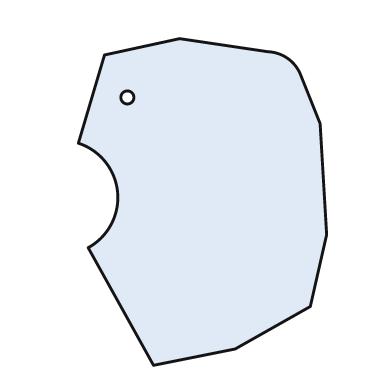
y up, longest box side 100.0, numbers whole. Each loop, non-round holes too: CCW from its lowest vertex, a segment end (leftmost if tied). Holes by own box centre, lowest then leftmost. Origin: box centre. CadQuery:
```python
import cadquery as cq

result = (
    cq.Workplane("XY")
    .moveTo(-15.0, -50.0)
    .lineTo(10.0, -45.0)
    .lineTo(33.0, -32.0)
    .lineTo(38.0, -10.0)
    .lineTo(36.0, 24.0)
    .lineTo(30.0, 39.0)
    .threePointArc((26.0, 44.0), (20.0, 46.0))
    .lineTo(-7.0, 50.0)
    .lineTo(-30.0, 45.0)
    .lineTo(-38.0, 18.0)
    .threePointArc((-26.0, 3.0), (-35.0, -14.0))
    .close()
    .moveTo(-23.0, 32.0)
    .circle(2.0)
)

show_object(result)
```